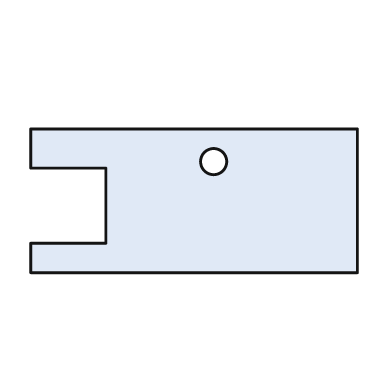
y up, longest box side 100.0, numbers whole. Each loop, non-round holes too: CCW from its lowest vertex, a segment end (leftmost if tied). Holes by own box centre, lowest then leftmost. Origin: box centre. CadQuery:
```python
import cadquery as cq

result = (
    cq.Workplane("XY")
    .moveTo(-50.0, -22.0)
    .lineTo(50.0, -22.0)
    .lineTo(50.0, 22.0)
    .lineTo(-50.0, 22.0)
    .lineTo(-50.0, 10.0)
    .lineTo(-27.0, 10.0)
    .lineTo(-27.0, -13.0)
    .lineTo(-50.0, -13.0)
    .close()
    .moveTo(6.0, 12.0)
    .circle(4.0)
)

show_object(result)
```